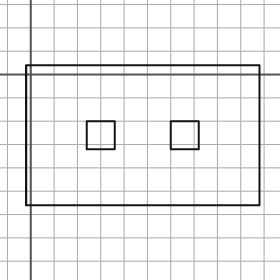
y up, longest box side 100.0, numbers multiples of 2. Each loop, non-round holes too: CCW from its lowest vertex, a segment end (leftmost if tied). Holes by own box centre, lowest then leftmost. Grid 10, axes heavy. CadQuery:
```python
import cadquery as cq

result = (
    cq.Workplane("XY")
    .moveTo(-2.0, -56.0)
    .lineTo(98.0, -56.0)
    .lineTo(98.0, 4.0)
    .lineTo(-2.0, 4.0)
    .close()
    .moveTo(24.0, -32.0)
    .lineTo(36.0, -32.0)
    .lineTo(36.0, -20.0)
    .lineTo(24.0, -20.0)
    .close()
    .moveTo(60.0, -32.0)
    .lineTo(72.0, -32.0)
    .lineTo(72.0, -20.0)
    .lineTo(60.0, -20.0)
    .close()
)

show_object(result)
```